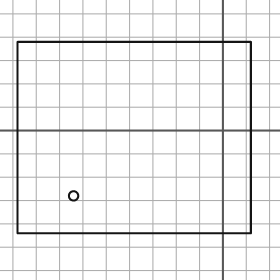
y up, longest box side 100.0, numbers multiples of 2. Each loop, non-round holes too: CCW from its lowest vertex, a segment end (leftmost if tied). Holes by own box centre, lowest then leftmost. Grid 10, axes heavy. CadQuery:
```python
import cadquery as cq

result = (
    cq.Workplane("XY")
    .moveTo(-88.0, -44.0)
    .lineTo(12.0, -44.0)
    .lineTo(12.0, 38.0)
    .lineTo(-88.0, 38.0)
    .close()
    .moveTo(-64.0, -28.0)
    .circle(2.0)
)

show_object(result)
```